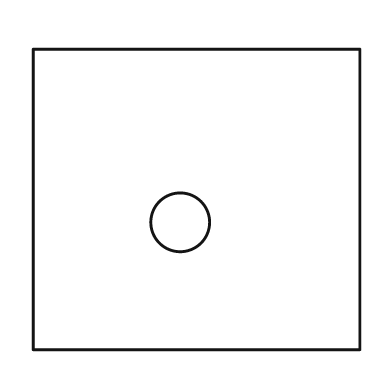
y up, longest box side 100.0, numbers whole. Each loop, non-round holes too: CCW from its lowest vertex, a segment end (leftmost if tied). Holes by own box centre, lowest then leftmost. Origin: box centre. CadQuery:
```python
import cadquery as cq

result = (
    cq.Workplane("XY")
    .moveTo(-50.0, -46.0)
    .lineTo(50.0, -46.0)
    .lineTo(50.0, 46.0)
    .lineTo(-50.0, 46.0)
    .close()
    .moveTo(-5.0, -7.0)
    .circle(9.0)
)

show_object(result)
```